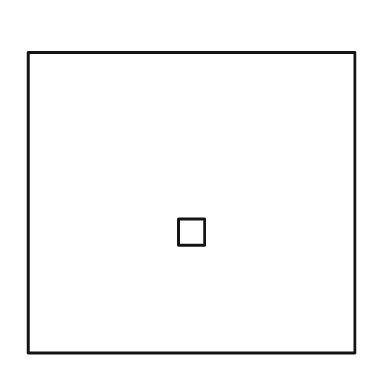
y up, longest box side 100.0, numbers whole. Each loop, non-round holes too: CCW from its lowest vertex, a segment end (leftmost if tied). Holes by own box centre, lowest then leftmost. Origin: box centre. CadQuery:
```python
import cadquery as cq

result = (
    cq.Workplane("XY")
    .moveTo(-50.0, -46.0)
    .lineTo(50.0, -46.0)
    .lineTo(50.0, 46.0)
    .lineTo(-50.0, 46.0)
    .close()
    .moveTo(-4.0, -13.0)
    .lineTo(4.0, -13.0)
    .lineTo(4.0, -5.0)
    .lineTo(-4.0, -5.0)
    .close()
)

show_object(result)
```